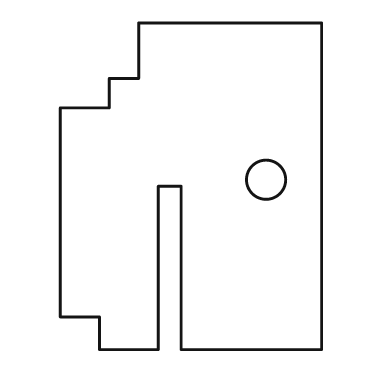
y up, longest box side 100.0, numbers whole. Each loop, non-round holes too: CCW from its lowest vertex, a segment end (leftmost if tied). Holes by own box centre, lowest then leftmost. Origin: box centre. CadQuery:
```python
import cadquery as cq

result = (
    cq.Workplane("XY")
    .moveTo(-28.0, -50.0)
    .lineTo(-10.0, -50.0)
    .lineTo(-10.0, 0.0)
    .lineTo(-3.0, 0.0)
    .lineTo(-3.0, -50.0)
    .lineTo(40.0, -50.0)
    .lineTo(40.0, 50.0)
    .lineTo(-16.0, 50.0)
    .lineTo(-16.0, 33.0)
    .lineTo(-25.0, 33.0)
    .lineTo(-25.0, 24.0)
    .lineTo(-40.0, 24.0)
    .lineTo(-40.0, -40.0)
    .lineTo(-28.0, -40.0)
    .close()
    .moveTo(23.0, 2.0)
    .circle(6.0)
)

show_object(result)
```